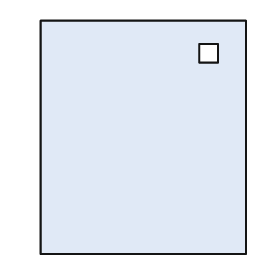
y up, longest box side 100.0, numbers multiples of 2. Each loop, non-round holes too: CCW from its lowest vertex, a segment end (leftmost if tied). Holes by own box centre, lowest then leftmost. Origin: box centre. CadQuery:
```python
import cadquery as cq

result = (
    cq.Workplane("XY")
    .moveTo(-44.0, -50.0)
    .lineTo(44.0, -50.0)
    .lineTo(44.0, 50.0)
    .lineTo(-44.0, 50.0)
    .close()
    .moveTo(24.0, 32.0)
    .lineTo(32.0, 32.0)
    .lineTo(32.0, 40.0)
    .lineTo(24.0, 40.0)
    .close()
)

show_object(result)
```